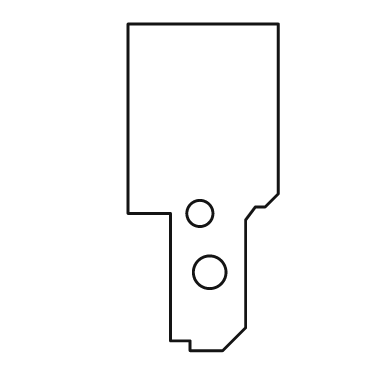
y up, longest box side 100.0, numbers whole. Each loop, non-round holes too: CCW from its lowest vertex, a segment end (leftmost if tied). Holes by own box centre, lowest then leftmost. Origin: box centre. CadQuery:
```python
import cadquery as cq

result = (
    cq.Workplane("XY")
    .moveTo(-4.0, -50.0)
    .lineTo(6.0, -50.0)
    .lineTo(13.0, -43.0)
    .lineTo(13.0, -10.0)
    .lineTo(16.0, -6.0)
    .lineTo(19.0, -6.0)
    .lineTo(23.0, -2.0)
    .lineTo(23.0, 50.0)
    .lineTo(-23.0, 50.0)
    .lineTo(-23.0, -8.0)
    .lineTo(-10.0, -8.0)
    .lineTo(-10.0, -47.0)
    .lineTo(-4.0, -47.0)
    .close()
    .moveTo(2.0, -26.0)
    .circle(5.0)
    .moveTo(-1.0, -8.0)
    .circle(4.0)
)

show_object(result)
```